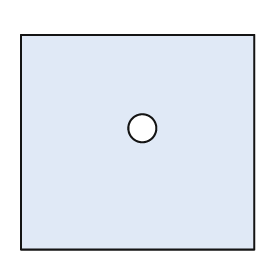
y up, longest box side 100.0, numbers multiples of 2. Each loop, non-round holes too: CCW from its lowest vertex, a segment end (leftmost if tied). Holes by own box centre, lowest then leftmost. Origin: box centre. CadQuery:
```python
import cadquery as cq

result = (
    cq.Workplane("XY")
    .moveTo(-50.0, -46.0)
    .lineTo(50.0, -46.0)
    .lineTo(50.0, 46.0)
    .lineTo(-50.0, 46.0)
    .close()
    .moveTo(2.0, 6.0)
    .circle(6.0)
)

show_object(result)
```